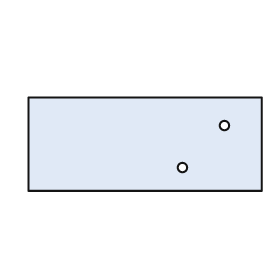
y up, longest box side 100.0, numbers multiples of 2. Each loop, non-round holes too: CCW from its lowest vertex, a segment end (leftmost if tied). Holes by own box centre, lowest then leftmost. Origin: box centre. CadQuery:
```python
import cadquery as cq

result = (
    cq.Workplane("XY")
    .moveTo(-50.0, -20.0)
    .lineTo(50.0, -20.0)
    .lineTo(50.0, 20.0)
    .lineTo(-50.0, 20.0)
    .close()
    .moveTo(16.0, -10.0)
    .circle(2.0)
    .moveTo(34.0, 8.0)
    .circle(2.0)
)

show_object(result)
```